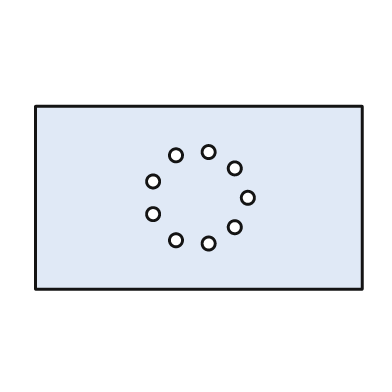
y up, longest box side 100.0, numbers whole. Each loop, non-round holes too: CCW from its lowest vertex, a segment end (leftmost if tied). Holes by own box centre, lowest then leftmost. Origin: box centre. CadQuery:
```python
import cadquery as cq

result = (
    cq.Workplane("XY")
    .moveTo(-50.0, -28.0)
    .lineTo(50.0, -28.0)
    .lineTo(50.0, 28.0)
    .lineTo(-50.0, 28.0)
    .close()
    .moveTo(3.0, -14.0)
    .circle(2.0)
    .moveTo(-7.0, -13.0)
    .circle(2.0)
    .moveTo(11.0, -9.0)
    .circle(2.0)
    .moveTo(-14.0, -5.0)
    .circle(2.0)
    .moveTo(15.0, 0.0)
    .circle(2.0)
    .moveTo(-14.0, 5.0)
    .circle(2.0)
    .moveTo(11.0, 9.0)
    .circle(2.0)
    .moveTo(-7.0, 13.0)
    .circle(2.0)
    .moveTo(3.0, 14.0)
    .circle(2.0)
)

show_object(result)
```